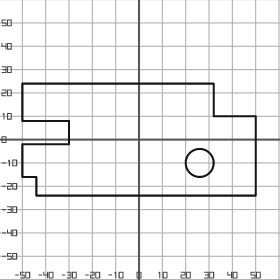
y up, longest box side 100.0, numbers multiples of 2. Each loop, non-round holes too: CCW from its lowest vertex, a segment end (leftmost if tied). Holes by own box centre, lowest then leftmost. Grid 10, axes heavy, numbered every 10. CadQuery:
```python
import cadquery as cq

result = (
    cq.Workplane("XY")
    .moveTo(-44.0, -24.0)
    .lineTo(50.0, -24.0)
    .lineTo(50.0, 10.0)
    .lineTo(32.0, 10.0)
    .lineTo(32.0, 24.0)
    .lineTo(-50.0, 24.0)
    .lineTo(-50.0, 8.0)
    .lineTo(-30.0, 8.0)
    .lineTo(-30.0, -2.0)
    .lineTo(-50.0, -2.0)
    .lineTo(-50.0, -16.0)
    .lineTo(-44.0, -16.0)
    .close()
    .moveTo(26.0, -10.0)
    .circle(6.0)
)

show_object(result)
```